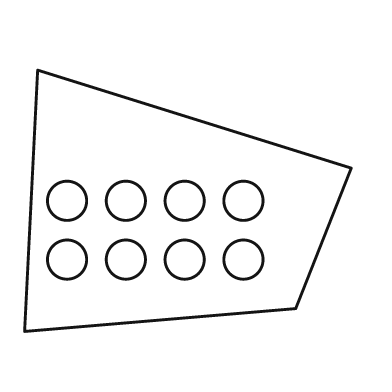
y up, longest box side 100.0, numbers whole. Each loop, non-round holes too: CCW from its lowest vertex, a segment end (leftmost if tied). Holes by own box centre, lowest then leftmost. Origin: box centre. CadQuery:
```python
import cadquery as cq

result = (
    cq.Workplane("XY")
    .moveTo(-50.0, -40.0)
    .lineTo(33.0, -33.0)
    .lineTo(50.0, 10.0)
    .lineTo(-46.0, 40.0)
    .close()
    .moveTo(-37.0, -18.0)
    .circle(6.0)
    .moveTo(-19.0, -18.0)
    .circle(6.0)
    .moveTo(-1.0, -18.0)
    .circle(6.0)
    .moveTo(17.0, -18.0)
    .circle(6.0)
    .moveTo(-37.0, 0.0)
    .circle(6.0)
    .moveTo(-19.0, 0.0)
    .circle(6.0)
    .moveTo(-1.0, 0.0)
    .circle(6.0)
    .moveTo(17.0, 0.0)
    .circle(6.0)
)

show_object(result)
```